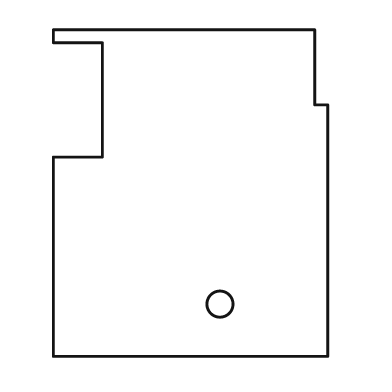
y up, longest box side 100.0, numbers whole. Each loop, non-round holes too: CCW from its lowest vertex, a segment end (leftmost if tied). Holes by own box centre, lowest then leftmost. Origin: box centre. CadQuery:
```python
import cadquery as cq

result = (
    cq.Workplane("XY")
    .moveTo(-42.0, -50.0)
    .lineTo(42.0, -50.0)
    .lineTo(42.0, 27.0)
    .lineTo(38.0, 27.0)
    .lineTo(38.0, 50.0)
    .lineTo(-42.0, 50.0)
    .lineTo(-42.0, 46.0)
    .lineTo(-27.0, 46.0)
    .lineTo(-27.0, 11.0)
    .lineTo(-42.0, 11.0)
    .close()
    .moveTo(9.0, -34.0)
    .circle(4.0)
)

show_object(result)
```